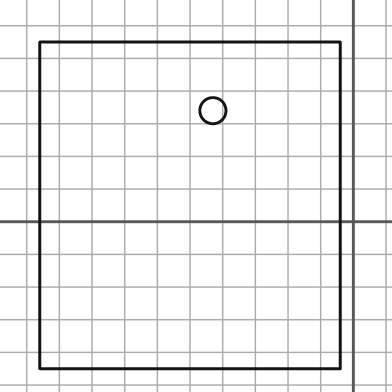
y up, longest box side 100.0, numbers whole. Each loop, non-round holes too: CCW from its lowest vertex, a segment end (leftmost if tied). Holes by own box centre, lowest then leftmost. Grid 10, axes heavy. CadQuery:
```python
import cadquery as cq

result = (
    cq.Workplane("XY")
    .moveTo(-96.0, -45.0)
    .lineTo(-4.0, -45.0)
    .lineTo(-4.0, 55.0)
    .lineTo(-96.0, 55.0)
    .close()
    .moveTo(-43.0, 34.0)
    .circle(4.0)
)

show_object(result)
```